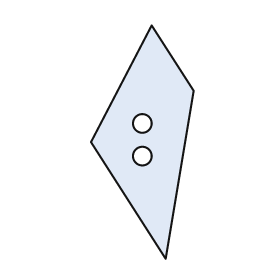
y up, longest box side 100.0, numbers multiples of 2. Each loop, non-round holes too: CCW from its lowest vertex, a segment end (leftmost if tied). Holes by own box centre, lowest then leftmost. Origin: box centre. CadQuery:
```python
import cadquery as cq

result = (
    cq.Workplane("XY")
    .moveTo(10.0, -50.0)
    .lineTo(22.0, 22.0)
    .lineTo(4.0, 50.0)
    .lineTo(-22.0, 0.0)
    .close()
    .moveTo(0.0, -6.0)
    .circle(4.0)
    .moveTo(0.0, 8.0)
    .circle(4.0)
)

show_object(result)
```